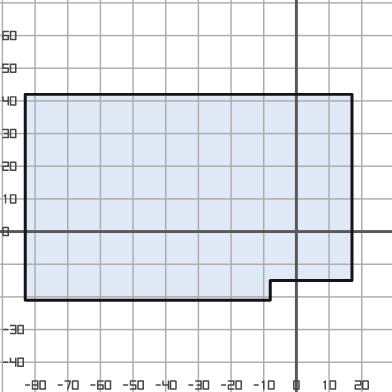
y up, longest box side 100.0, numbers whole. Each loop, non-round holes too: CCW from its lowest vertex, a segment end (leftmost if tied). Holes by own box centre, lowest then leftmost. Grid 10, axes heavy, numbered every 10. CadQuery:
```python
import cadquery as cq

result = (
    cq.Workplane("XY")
    .moveTo(-83.0, -21.0)
    .lineTo(-8.0, -21.0)
    .lineTo(-8.0, -15.0)
    .lineTo(17.0, -15.0)
    .lineTo(17.0, 42.0)
    .lineTo(-83.0, 42.0)
    .close()
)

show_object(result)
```